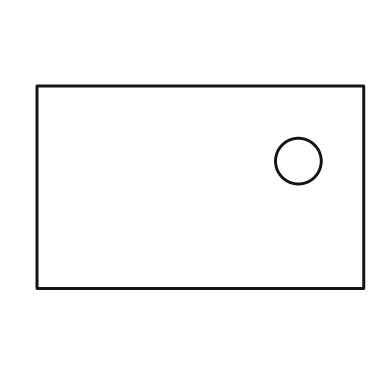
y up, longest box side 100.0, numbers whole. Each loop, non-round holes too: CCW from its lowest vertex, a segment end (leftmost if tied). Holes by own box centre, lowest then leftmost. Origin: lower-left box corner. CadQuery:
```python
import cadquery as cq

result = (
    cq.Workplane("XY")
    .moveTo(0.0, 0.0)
    .lineTo(100.0, 0.0)
    .lineTo(100.0, 62.0)
    .lineTo(0.0, 62.0)
    .close()
    .moveTo(80.0, 39.0)
    .circle(7.0)
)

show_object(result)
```